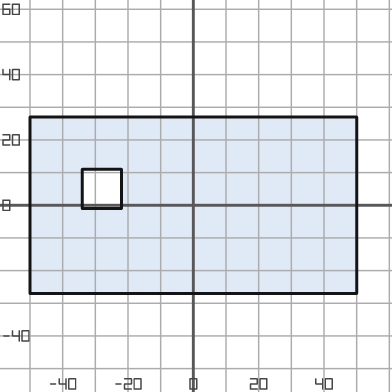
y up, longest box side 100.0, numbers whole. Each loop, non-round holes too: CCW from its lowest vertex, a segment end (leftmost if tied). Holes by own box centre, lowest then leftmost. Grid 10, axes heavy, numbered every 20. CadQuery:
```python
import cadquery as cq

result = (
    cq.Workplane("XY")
    .moveTo(-50.0, -27.0)
    .lineTo(50.0, -27.0)
    .lineTo(50.0, 27.0)
    .lineTo(-50.0, 27.0)
    .close()
    .moveTo(-34.0, -1.0)
    .lineTo(-22.0, -1.0)
    .lineTo(-22.0, 11.0)
    .lineTo(-34.0, 11.0)
    .close()
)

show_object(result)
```